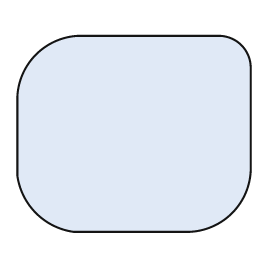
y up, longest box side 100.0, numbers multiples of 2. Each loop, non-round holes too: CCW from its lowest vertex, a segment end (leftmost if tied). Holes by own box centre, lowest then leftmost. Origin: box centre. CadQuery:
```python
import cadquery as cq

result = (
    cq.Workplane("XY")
    .moveTo(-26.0, -42.0)
    .lineTo(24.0, -42.0)
    .threePointArc((42.0, -34.0), (50.0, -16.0))
    .lineTo(50.0, 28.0)
    .threePointArc((46.0, 38.0), (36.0, 42.0))
    .lineTo(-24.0, 42.0)
    .threePointArc((-42.0, 34.0), (-50.0, 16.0))
    .lineTo(-50.0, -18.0)
    .threePointArc((-42.0, -34.0), (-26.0, -42.0))
    .close()
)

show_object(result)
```